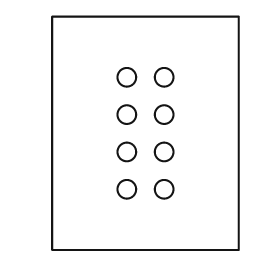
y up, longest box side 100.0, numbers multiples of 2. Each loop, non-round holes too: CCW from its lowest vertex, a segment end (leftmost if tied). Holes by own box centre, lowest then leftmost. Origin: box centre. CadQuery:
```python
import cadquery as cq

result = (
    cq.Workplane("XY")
    .moveTo(-40.0, -50.0)
    .lineTo(40.0, -50.0)
    .lineTo(40.0, 50.0)
    .lineTo(-40.0, 50.0)
    .close()
    .moveTo(-8.0, -24.0)
    .circle(4.0)
    .moveTo(8.0, -24.0)
    .circle(4.0)
    .moveTo(-8.0, -8.0)
    .circle(4.0)
    .moveTo(8.0, -8.0)
    .circle(4.0)
    .moveTo(-8.0, 8.0)
    .circle(4.0)
    .moveTo(8.0, 8.0)
    .circle(4.0)
    .moveTo(-8.0, 24.0)
    .circle(4.0)
    .moveTo(8.0, 24.0)
    .circle(4.0)
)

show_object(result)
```